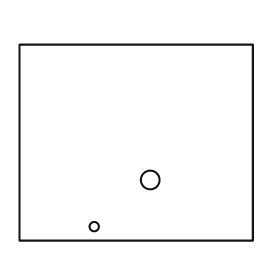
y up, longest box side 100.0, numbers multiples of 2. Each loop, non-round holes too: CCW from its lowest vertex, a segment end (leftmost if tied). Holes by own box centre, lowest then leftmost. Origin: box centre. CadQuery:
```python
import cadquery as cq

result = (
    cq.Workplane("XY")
    .moveTo(-50.0, -42.0)
    .lineTo(50.0, -42.0)
    .lineTo(50.0, 42.0)
    .lineTo(-50.0, 42.0)
    .close()
    .moveTo(-18.0, -36.0)
    .circle(2.0)
    .moveTo(6.0, -16.0)
    .circle(4.0)
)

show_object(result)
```